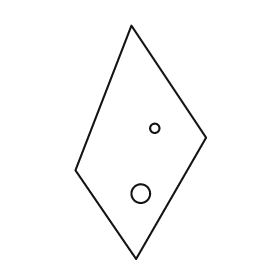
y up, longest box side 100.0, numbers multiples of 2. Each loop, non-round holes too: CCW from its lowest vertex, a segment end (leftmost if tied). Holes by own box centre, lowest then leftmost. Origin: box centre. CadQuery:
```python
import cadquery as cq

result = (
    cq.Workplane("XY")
    .moveTo(-2.0, -50.0)
    .lineTo(28.0, 2.0)
    .lineTo(-4.0, 50.0)
    .lineTo(-28.0, -12.0)
    .close()
    .moveTo(0.0, -22.0)
    .circle(4.0)
    .moveTo(6.0, 6.0)
    .circle(2.0)
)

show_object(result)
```